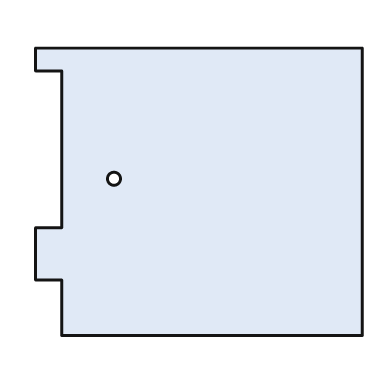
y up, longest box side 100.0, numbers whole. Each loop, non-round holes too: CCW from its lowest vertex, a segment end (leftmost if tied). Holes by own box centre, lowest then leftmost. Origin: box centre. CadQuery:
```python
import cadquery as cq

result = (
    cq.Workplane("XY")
    .moveTo(-42.0, -44.0)
    .lineTo(50.0, -44.0)
    .lineTo(50.0, 44.0)
    .lineTo(-50.0, 44.0)
    .lineTo(-50.0, 37.0)
    .lineTo(-42.0, 37.0)
    .lineTo(-42.0, -11.0)
    .lineTo(-50.0, -11.0)
    .lineTo(-50.0, -27.0)
    .lineTo(-42.0, -27.0)
    .close()
    .moveTo(-26.0, 4.0)
    .circle(2.0)
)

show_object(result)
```